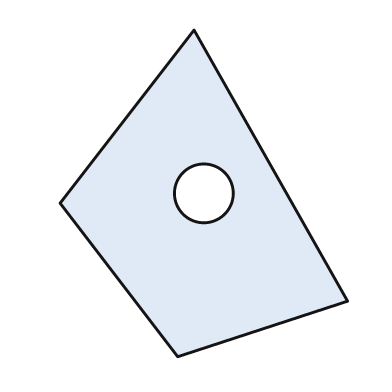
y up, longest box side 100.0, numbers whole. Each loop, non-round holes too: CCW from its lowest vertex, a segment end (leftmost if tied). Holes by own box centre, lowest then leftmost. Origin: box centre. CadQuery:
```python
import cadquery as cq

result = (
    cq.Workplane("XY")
    .moveTo(-8.0, -50.0)
    .lineTo(44.0, -33.0)
    .lineTo(-3.0, 50.0)
    .lineTo(-44.0, -3.0)
    .close()
    .moveTo(0.0, 0.0)
    .circle(9.0)
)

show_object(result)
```